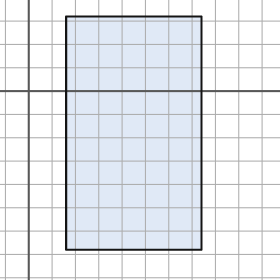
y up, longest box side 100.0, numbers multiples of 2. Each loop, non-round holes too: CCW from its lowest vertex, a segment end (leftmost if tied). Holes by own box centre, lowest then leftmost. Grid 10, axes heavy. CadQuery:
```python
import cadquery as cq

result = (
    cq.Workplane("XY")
    .moveTo(16.0, -68.0)
    .lineTo(74.0, -68.0)
    .lineTo(74.0, 32.0)
    .lineTo(16.0, 32.0)
    .close()
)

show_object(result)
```